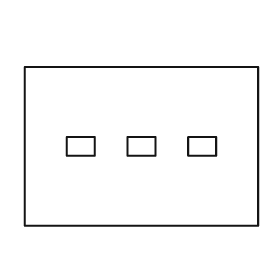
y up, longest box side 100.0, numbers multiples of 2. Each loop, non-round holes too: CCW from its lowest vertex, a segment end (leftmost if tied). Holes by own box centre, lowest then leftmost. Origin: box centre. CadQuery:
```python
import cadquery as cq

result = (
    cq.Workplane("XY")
    .moveTo(-50.0, -34.0)
    .lineTo(50.0, -34.0)
    .lineTo(50.0, 34.0)
    .lineTo(-50.0, 34.0)
    .close()
    .moveTo(-32.0, -4.0)
    .lineTo(-20.0, -4.0)
    .lineTo(-20.0, 4.0)
    .lineTo(-32.0, 4.0)
    .close()
    .moveTo(-6.0, -4.0)
    .lineTo(6.0, -4.0)
    .lineTo(6.0, 4.0)
    .lineTo(-6.0, 4.0)
    .close()
    .moveTo(20.0, -4.0)
    .lineTo(32.0, -4.0)
    .lineTo(32.0, 4.0)
    .lineTo(20.0, 4.0)
    .close()
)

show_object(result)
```